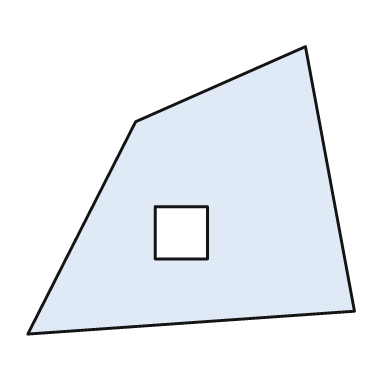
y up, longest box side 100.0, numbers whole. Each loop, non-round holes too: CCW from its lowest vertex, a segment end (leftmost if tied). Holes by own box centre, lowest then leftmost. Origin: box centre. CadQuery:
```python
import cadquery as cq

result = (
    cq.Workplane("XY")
    .moveTo(-50.0, -44.0)
    .lineTo(50.0, -37.0)
    .lineTo(35.0, 44.0)
    .lineTo(-17.0, 21.0)
    .close()
    .moveTo(-11.0, -21.0)
    .lineTo(5.0, -21.0)
    .lineTo(5.0, -5.0)
    .lineTo(-11.0, -5.0)
    .close()
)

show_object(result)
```